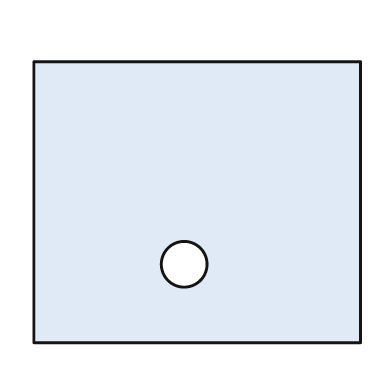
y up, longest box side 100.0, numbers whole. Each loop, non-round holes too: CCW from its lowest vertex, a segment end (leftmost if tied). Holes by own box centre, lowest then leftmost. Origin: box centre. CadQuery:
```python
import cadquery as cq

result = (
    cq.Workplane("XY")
    .moveTo(-50.0, -43.0)
    .lineTo(50.0, -43.0)
    .lineTo(50.0, 43.0)
    .lineTo(-50.0, 43.0)
    .close()
    .moveTo(-4.0, -19.0)
    .circle(7.0)
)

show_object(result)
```